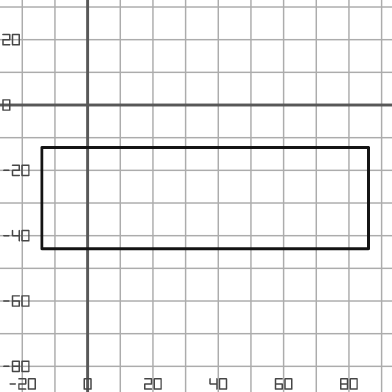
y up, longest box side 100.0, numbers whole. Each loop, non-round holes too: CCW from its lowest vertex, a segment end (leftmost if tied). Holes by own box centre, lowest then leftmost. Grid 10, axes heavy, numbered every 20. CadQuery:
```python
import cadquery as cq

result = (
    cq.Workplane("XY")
    .moveTo(-14.0, -44.0)
    .lineTo(86.0, -44.0)
    .lineTo(86.0, -13.0)
    .lineTo(-14.0, -13.0)
    .close()
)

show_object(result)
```